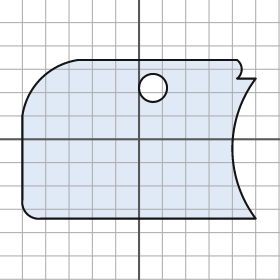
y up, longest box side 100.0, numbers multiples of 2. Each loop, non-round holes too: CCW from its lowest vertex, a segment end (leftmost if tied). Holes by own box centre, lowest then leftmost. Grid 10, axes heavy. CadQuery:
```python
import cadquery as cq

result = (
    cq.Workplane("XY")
    .moveTo(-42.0, -34.0)
    .lineTo(50.0, -34.0)
    .threePointArc((40.0, -4.0), (50.0, 26.0))
    .lineTo(42.0, 26.0)
    .threePointArc((44.0, 30.0), (42.0, 34.0))
    .lineTo(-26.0, 34.0)
    .threePointArc((-42.0, 26.0), (-50.0, 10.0))
    .lineTo(-50.0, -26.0)
    .threePointArc((-48.0, -32.0), (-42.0, -34.0))
    .close()
    .moveTo(6.0, 22.0)
    .circle(6.0)
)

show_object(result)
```